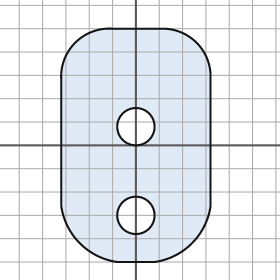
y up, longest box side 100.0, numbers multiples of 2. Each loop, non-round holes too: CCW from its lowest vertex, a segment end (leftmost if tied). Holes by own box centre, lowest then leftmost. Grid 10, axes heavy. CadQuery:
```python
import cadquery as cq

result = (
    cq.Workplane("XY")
    .moveTo(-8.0, -50.0)
    .lineTo(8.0, -50.0)
    .threePointArc((24.0, -42.0), (32.0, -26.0))
    .lineTo(32.0, 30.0)
    .threePointArc((26.0, 44.0), (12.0, 50.0))
    .lineTo(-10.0, 50.0)
    .threePointArc((-26.0, 44.0), (-32.0, 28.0))
    .lineTo(-32.0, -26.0)
    .threePointArc((-24.0, -42.0), (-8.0, -50.0))
    .close()
    .moveTo(0.0, -30.0)
    .circle(8.0)
    .moveTo(0.0, 8.0)
    .circle(8.0)
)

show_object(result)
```